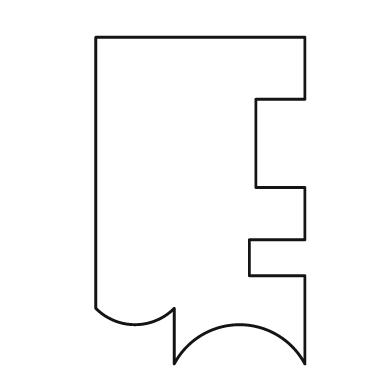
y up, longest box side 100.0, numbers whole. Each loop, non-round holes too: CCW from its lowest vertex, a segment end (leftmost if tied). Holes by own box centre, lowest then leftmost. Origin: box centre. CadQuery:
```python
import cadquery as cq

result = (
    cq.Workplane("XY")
    .moveTo(-8.0, -50.0)
    .threePointArc((12.0, -38.0), (32.0, -50.0))
    .lineTo(32.0, -23.0)
    .lineTo(15.0, -23.0)
    .lineTo(15.0, -12.0)
    .lineTo(32.0, -12.0)
    .lineTo(32.0, 4.0)
    .lineTo(17.0, 4.0)
    .lineTo(17.0, 31.0)
    .lineTo(32.0, 31.0)
    .lineTo(32.0, 50.0)
    .lineTo(-32.0, 50.0)
    .lineTo(-32.0, -33.0)
    .threePointArc((-20.0, -38.0), (-8.0, -33.0))
    .close()
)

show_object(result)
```